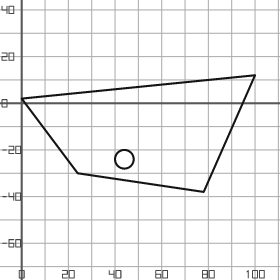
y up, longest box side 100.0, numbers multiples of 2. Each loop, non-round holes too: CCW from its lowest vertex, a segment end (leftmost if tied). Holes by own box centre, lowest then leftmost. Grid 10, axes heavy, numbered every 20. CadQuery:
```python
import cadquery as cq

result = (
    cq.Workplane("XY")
    .moveTo(78.0, -38.0)
    .lineTo(100.0, 12.0)
    .lineTo(0.0, 2.0)
    .lineTo(24.0, -30.0)
    .close()
    .moveTo(44.0, -24.0)
    .circle(4.0)
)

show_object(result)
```